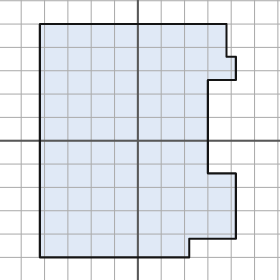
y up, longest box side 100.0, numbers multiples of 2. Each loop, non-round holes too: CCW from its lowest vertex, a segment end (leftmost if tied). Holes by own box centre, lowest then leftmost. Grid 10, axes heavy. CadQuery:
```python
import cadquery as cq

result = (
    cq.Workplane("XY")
    .moveTo(-42.0, -50.0)
    .lineTo(22.0, -50.0)
    .lineTo(22.0, -42.0)
    .lineTo(42.0, -42.0)
    .lineTo(42.0, -14.0)
    .lineTo(30.0, -14.0)
    .lineTo(30.0, 26.0)
    .lineTo(42.0, 26.0)
    .lineTo(42.0, 36.0)
    .lineTo(38.0, 36.0)
    .lineTo(38.0, 50.0)
    .lineTo(-42.0, 50.0)
    .close()
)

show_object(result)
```